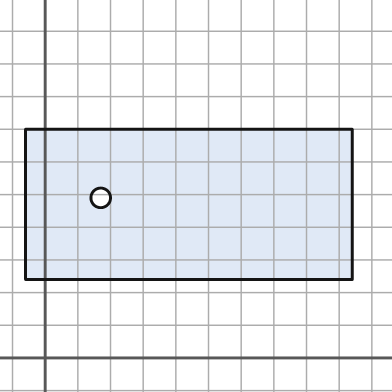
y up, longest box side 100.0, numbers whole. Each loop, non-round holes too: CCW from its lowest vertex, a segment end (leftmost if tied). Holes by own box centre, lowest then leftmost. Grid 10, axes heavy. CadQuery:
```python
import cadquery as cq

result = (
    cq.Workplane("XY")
    .moveTo(-6.0, 24.0)
    .lineTo(94.0, 24.0)
    .lineTo(94.0, 70.0)
    .lineTo(-6.0, 70.0)
    .close()
    .moveTo(17.0, 49.0)
    .circle(3.0)
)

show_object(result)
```